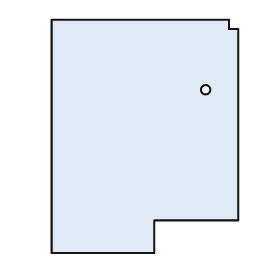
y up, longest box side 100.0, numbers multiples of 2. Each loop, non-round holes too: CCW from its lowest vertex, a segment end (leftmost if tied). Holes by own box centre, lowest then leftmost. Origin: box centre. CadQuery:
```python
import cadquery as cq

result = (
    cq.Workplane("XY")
    .moveTo(-40.0, -50.0)
    .lineTo(4.0, -50.0)
    .lineTo(4.0, -36.0)
    .lineTo(40.0, -36.0)
    .lineTo(40.0, 46.0)
    .lineTo(36.0, 46.0)
    .lineTo(36.0, 50.0)
    .lineTo(-40.0, 50.0)
    .close()
    .moveTo(26.0, 20.0)
    .circle(2.0)
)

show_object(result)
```